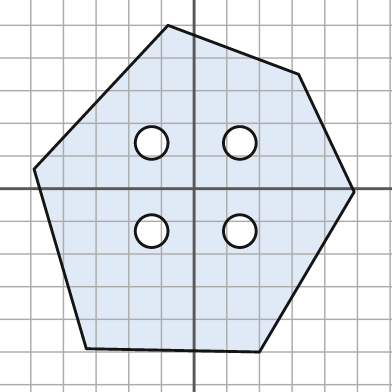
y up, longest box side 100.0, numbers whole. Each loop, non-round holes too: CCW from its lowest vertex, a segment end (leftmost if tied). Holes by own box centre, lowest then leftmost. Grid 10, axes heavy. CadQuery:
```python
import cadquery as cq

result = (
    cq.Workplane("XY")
    .moveTo(20.0, -50.0)
    .lineTo(49.0, -1.0)
    .lineTo(32.0, 35.0)
    .lineTo(-8.0, 50.0)
    .lineTo(-49.0, 6.0)
    .lineTo(-33.0, -49.0)
    .close()
    .moveTo(-13.0, -13.0)
    .circle(5.0)
    .moveTo(14.0, -13.0)
    .circle(5.0)
    .moveTo(-13.0, 14.0)
    .circle(5.0)
    .moveTo(14.0, 14.0)
    .circle(5.0)
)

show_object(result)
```